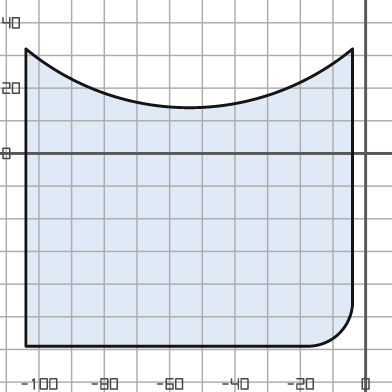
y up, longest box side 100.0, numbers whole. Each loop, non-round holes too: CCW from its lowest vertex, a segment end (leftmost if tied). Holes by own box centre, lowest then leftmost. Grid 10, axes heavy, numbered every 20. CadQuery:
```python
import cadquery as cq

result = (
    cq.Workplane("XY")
    .moveTo(-104.0, -59.0)
    .lineTo(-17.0, -59.0)
    .threePointArc((-8.0, -55.0), (-4.0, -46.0))
    .lineTo(-4.0, 32.0)
    .threePointArc((-54.0, 14.0), (-104.0, 32.0))
    .close()
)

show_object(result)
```